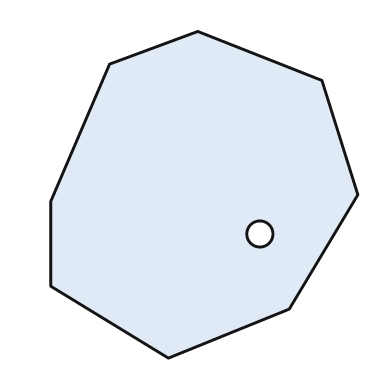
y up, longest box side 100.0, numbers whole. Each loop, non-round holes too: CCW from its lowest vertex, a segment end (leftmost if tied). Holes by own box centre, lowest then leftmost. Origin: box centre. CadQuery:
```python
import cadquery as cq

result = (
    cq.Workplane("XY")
    .moveTo(-11.0, -50.0)
    .lineTo(26.0, -35.0)
    .lineTo(47.0, 0.0)
    .lineTo(36.0, 35.0)
    .lineTo(-2.0, 50.0)
    .lineTo(-29.0, 40.0)
    .lineTo(-47.0, -2.0)
    .lineTo(-47.0, -28.0)
    .close()
    .moveTo(17.0, -12.0)
    .circle(4.0)
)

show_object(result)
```